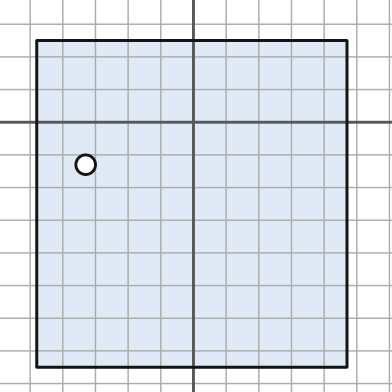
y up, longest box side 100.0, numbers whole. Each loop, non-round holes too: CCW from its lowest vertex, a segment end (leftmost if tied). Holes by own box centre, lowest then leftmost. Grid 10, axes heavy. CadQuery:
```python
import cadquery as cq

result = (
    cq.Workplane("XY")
    .moveTo(-48.0, -75.0)
    .lineTo(47.0, -75.0)
    .lineTo(47.0, 25.0)
    .lineTo(-48.0, 25.0)
    .close()
    .moveTo(-33.0, -13.0)
    .circle(3.0)
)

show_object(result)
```